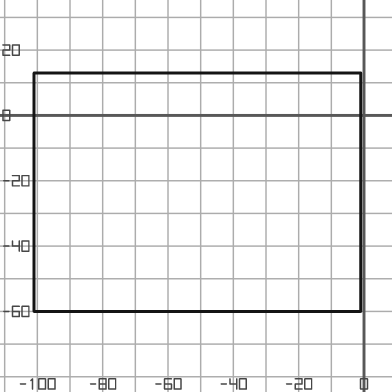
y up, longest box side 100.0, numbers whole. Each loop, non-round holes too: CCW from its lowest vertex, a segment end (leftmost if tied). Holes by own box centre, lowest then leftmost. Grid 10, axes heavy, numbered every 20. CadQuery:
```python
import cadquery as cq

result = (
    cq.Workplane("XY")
    .moveTo(-101.0, -60.0)
    .lineTo(-1.0, -60.0)
    .lineTo(-1.0, 13.0)
    .lineTo(-101.0, 13.0)
    .close()
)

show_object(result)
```